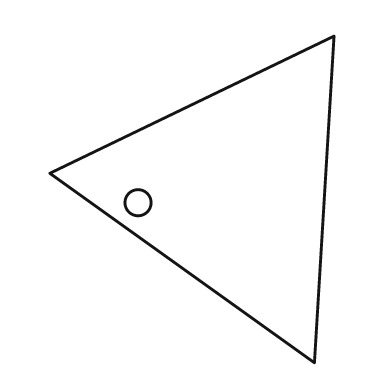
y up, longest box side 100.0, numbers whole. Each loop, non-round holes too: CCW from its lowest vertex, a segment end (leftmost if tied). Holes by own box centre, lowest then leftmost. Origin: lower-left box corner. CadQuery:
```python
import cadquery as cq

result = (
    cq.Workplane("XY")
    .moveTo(81.0, 0.0)
    .lineTo(87.0, 100.0)
    .lineTo(0.0, 58.0)
    .close()
    .moveTo(27.0, 49.0)
    .circle(4.0)
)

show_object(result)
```